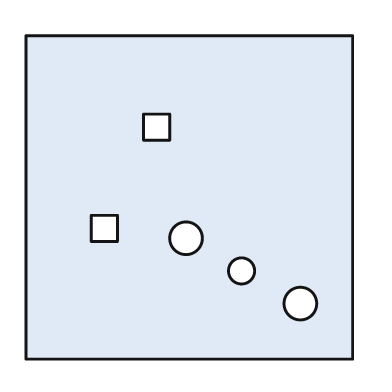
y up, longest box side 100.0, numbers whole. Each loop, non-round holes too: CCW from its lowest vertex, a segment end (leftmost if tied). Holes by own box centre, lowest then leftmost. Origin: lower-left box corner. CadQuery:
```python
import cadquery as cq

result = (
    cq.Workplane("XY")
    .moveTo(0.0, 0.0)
    .lineTo(100.0, 0.0)
    .lineTo(100.0, 99.0)
    .lineTo(0.0, 99.0)
    .close()
    .moveTo(84.0, 17.0)
    .circle(5.0)
    .moveTo(66.0, 27.0)
    .circle(4.0)
    .moveTo(49.0, 37.0)
    .circle(5.0)
    .moveTo(20.0, 36.0)
    .lineTo(28.0, 36.0)
    .lineTo(28.0, 44.0)
    .lineTo(20.0, 44.0)
    .close()
    .moveTo(36.0, 67.0)
    .lineTo(44.0, 67.0)
    .lineTo(44.0, 75.0)
    .lineTo(36.0, 75.0)
    .close()
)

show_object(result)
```